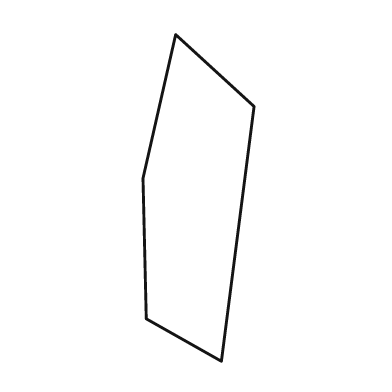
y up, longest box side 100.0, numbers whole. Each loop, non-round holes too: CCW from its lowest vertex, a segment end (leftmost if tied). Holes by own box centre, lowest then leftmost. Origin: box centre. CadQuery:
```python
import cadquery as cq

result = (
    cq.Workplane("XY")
    .moveTo(7.0, -50.0)
    .lineTo(17.0, 28.0)
    .lineTo(-7.0, 50.0)
    .lineTo(-17.0, 6.0)
    .lineTo(-16.0, -37.0)
    .close()
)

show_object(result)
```